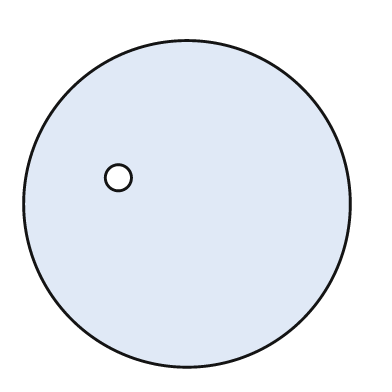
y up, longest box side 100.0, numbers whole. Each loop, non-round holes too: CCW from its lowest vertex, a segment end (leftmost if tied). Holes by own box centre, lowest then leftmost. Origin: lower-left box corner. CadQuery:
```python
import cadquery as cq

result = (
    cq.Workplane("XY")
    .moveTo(50.0, 50.0)
    .circle(50.0)
    .moveTo(29.0, 58.0)
    .circle(4.0)
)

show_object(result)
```